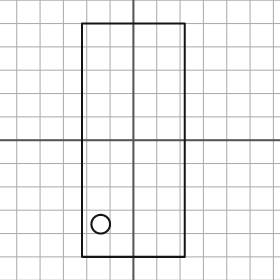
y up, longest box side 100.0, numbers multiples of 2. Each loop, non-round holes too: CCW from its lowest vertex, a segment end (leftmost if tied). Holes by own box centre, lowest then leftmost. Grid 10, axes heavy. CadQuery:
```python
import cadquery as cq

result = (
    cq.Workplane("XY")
    .moveTo(-22.0, -50.0)
    .lineTo(22.0, -50.0)
    .lineTo(22.0, 50.0)
    .lineTo(-22.0, 50.0)
    .close()
    .moveTo(-14.0, -36.0)
    .circle(4.0)
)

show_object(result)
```